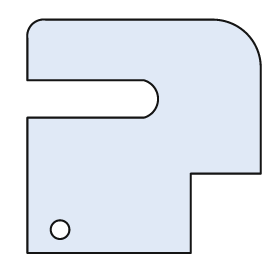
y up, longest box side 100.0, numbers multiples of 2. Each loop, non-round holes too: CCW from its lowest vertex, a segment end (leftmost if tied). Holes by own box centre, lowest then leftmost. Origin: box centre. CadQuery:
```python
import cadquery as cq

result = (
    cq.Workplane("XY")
    .moveTo(-50.0, -50.0)
    .lineTo(20.0, -50.0)
    .lineTo(20.0, -16.0)
    .lineTo(50.0, -16.0)
    .lineTo(50.0, 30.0)
    .threePointArc((44.0, 44.0), (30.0, 50.0))
    .lineTo(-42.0, 50.0)
    .threePointArc((-48.0, 48.0), (-50.0, 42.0))
    .lineTo(-50.0, 24.0)
    .lineTo(0.0, 24.0)
    .threePointArc((6.0, 16.0), (0.0, 8.0))
    .lineTo(-50.0, 8.0)
    .close()
    .moveTo(-36.0, -40.0)
    .circle(4.0)
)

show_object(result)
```